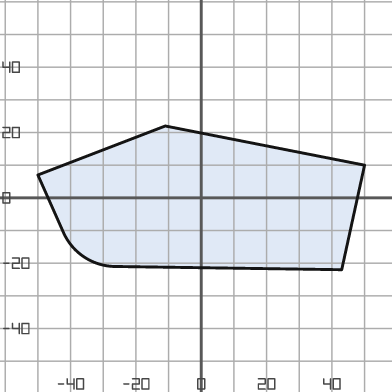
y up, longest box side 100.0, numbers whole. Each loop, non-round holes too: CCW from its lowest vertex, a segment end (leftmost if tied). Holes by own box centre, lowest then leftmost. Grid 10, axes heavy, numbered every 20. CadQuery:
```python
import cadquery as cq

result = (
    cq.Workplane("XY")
    .moveTo(43.0, -22.0)
    .lineTo(50.0, 10.0)
    .lineTo(-11.0, 22.0)
    .lineTo(-50.0, 7.0)
    .lineTo(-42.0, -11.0)
    .threePointArc((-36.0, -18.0), (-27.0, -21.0))
    .close()
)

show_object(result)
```